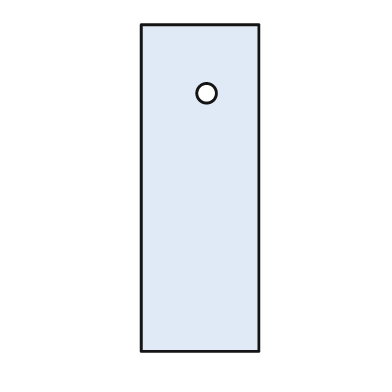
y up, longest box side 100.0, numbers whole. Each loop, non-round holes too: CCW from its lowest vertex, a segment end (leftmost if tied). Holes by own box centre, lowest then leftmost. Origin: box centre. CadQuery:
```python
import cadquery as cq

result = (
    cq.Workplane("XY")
    .moveTo(-18.0, -50.0)
    .lineTo(18.0, -50.0)
    .lineTo(18.0, 50.0)
    .lineTo(-18.0, 50.0)
    .close()
    .moveTo(2.0, 29.0)
    .circle(3.0)
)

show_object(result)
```